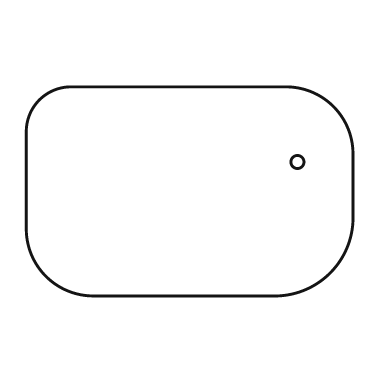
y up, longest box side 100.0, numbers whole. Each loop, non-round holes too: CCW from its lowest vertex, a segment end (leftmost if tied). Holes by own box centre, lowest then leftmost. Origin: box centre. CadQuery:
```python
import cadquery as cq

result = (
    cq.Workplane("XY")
    .moveTo(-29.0, -32.0)
    .lineTo(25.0, -32.0)
    .threePointArc((43.0, -25.0), (50.0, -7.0))
    .lineTo(50.0, 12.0)
    .threePointArc((44.0, 26.0), (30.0, 32.0))
    .lineTo(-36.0, 32.0)
    .threePointArc((-46.0, 28.0), (-50.0, 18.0))
    .lineTo(-50.0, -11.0)
    .threePointArc((-44.0, -26.0), (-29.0, -32.0))
    .close()
    .moveTo(33.0, 9.0)
    .circle(2.0)
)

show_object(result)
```